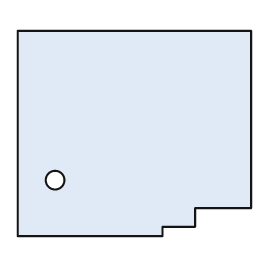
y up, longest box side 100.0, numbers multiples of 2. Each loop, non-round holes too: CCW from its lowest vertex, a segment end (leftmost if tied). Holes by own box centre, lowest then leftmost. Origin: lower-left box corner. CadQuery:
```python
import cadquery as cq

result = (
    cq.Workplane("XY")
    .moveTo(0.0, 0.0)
    .lineTo(62.0, 0.0)
    .lineTo(62.0, 4.0)
    .lineTo(76.0, 4.0)
    .lineTo(76.0, 12.0)
    .lineTo(100.0, 12.0)
    .lineTo(100.0, 88.0)
    .lineTo(0.0, 88.0)
    .close()
    .moveTo(16.0, 24.0)
    .circle(4.0)
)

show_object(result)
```